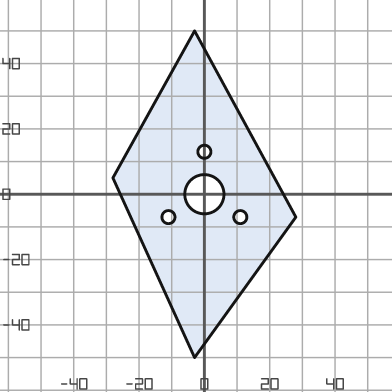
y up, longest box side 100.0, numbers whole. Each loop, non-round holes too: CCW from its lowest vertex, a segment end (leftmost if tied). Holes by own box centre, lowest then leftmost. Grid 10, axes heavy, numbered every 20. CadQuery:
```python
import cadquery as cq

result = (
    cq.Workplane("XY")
    .moveTo(-3.0, -50.0)
    .lineTo(28.0, -7.0)
    .lineTo(-3.0, 50.0)
    .lineTo(-28.0, 5.0)
    .close()
    .moveTo(-11.0, -7.0)
    .circle(2.0)
    .moveTo(11.0, -7.0)
    .circle(2.0)
    .moveTo(0.0, 0.0)
    .circle(6.0)
    .moveTo(0.0, 13.0)
    .circle(2.0)
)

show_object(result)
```